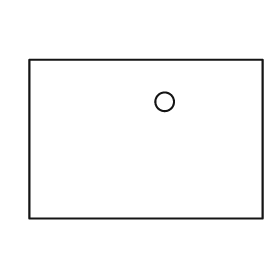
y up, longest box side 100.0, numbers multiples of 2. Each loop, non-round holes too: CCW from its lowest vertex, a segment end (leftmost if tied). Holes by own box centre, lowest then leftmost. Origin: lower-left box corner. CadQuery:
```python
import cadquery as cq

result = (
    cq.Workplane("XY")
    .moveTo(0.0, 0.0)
    .lineTo(100.0, 0.0)
    .lineTo(100.0, 68.0)
    .lineTo(0.0, 68.0)
    .close()
    .moveTo(58.0, 50.0)
    .circle(4.0)
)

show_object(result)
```